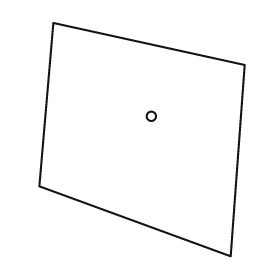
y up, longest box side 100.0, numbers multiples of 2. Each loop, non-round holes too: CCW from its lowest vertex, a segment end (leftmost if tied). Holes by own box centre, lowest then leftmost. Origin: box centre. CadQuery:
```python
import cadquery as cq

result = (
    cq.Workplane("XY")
    .moveTo(38.0, -50.0)
    .lineTo(44.0, 32.0)
    .lineTo(-38.0, 50.0)
    .lineTo(-44.0, -20.0)
    .close()
    .moveTo(4.0, 10.0)
    .circle(2.0)
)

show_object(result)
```